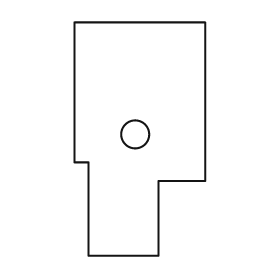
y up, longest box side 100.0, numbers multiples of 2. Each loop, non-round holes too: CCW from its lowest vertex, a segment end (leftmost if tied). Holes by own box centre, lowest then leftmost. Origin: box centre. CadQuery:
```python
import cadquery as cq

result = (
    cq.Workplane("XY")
    .moveTo(-22.0, -50.0)
    .lineTo(8.0, -50.0)
    .lineTo(8.0, -18.0)
    .lineTo(28.0, -18.0)
    .lineTo(28.0, 50.0)
    .lineTo(-28.0, 50.0)
    .lineTo(-28.0, -10.0)
    .lineTo(-22.0, -10.0)
    .close()
    .moveTo(-2.0, 2.0)
    .circle(6.0)
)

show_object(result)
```